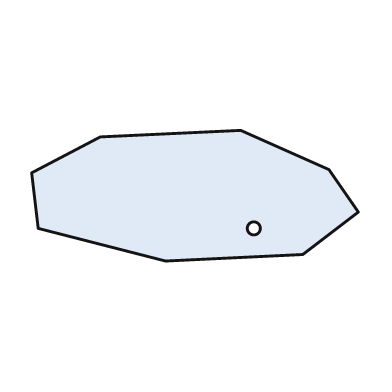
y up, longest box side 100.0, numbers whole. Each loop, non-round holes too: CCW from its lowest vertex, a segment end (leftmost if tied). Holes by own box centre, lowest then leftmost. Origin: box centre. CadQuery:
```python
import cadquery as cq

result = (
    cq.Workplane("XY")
    .moveTo(-9.0, -20.0)
    .lineTo(33.0, -18.0)
    .lineTo(50.0, -5.0)
    .lineTo(41.0, 8.0)
    .lineTo(14.0, 20.0)
    .lineTo(-29.0, 18.0)
    .lineTo(-50.0, 7.0)
    .lineTo(-48.0, -10.0)
    .close()
    .moveTo(18.0, -10.0)
    .circle(2.0)
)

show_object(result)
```